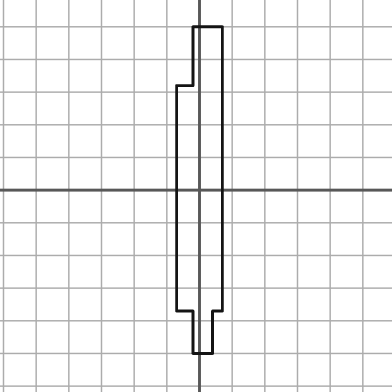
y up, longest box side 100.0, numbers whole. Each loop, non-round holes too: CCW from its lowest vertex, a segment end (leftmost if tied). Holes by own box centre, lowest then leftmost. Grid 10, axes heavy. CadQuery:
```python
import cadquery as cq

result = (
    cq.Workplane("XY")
    .moveTo(-2.0, -50.0)
    .lineTo(4.0, -50.0)
    .lineTo(4.0, -37.0)
    .lineTo(7.0, -37.0)
    .lineTo(7.0, 50.0)
    .lineTo(-2.0, 50.0)
    .lineTo(-2.0, 32.0)
    .lineTo(-7.0, 32.0)
    .lineTo(-7.0, -37.0)
    .lineTo(-2.0, -37.0)
    .close()
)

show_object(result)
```